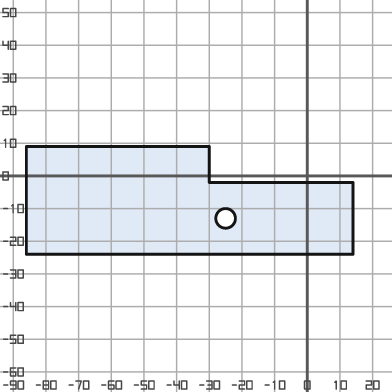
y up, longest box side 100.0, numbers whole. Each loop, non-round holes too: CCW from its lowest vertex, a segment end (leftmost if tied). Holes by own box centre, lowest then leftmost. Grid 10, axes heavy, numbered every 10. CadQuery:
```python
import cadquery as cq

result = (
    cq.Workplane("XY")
    .moveTo(-86.0, -24.0)
    .lineTo(14.0, -24.0)
    .lineTo(14.0, -2.0)
    .lineTo(-30.0, -2.0)
    .lineTo(-30.0, 9.0)
    .lineTo(-86.0, 9.0)
    .close()
    .moveTo(-25.0, -13.0)
    .circle(3.0)
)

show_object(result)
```